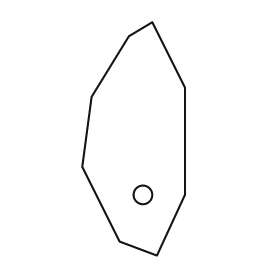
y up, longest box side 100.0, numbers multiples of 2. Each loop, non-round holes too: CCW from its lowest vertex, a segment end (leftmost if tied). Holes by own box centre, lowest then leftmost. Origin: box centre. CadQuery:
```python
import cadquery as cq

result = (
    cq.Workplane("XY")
    .moveTo(10.0, -50.0)
    .lineTo(22.0, -24.0)
    .lineTo(22.0, 22.0)
    .lineTo(8.0, 50.0)
    .lineTo(-2.0, 44.0)
    .lineTo(-18.0, 18.0)
    .lineTo(-22.0, -12.0)
    .lineTo(-6.0, -44.0)
    .close()
    .moveTo(4.0, -24.0)
    .circle(4.0)
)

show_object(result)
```